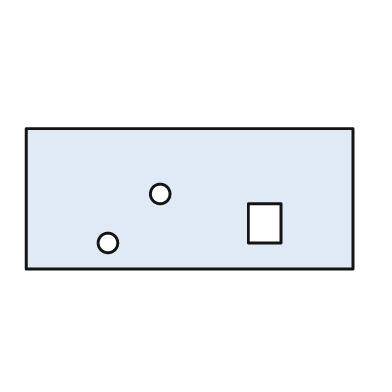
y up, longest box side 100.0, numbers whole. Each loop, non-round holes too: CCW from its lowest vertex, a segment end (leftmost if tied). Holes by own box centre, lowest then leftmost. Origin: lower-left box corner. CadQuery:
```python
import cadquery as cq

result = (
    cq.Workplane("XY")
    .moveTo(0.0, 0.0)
    .lineTo(100.0, 0.0)
    .lineTo(100.0, 43.0)
    .lineTo(0.0, 43.0)
    .close()
    .moveTo(25.0, 8.0)
    .circle(3.0)
    .moveTo(68.0, 8.0)
    .lineTo(78.0, 8.0)
    .lineTo(78.0, 20.0)
    .lineTo(68.0, 20.0)
    .close()
    .moveTo(41.0, 23.0)
    .circle(3.0)
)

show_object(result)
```